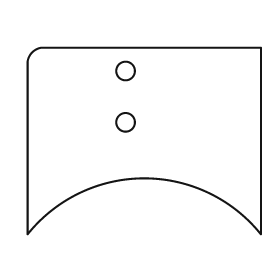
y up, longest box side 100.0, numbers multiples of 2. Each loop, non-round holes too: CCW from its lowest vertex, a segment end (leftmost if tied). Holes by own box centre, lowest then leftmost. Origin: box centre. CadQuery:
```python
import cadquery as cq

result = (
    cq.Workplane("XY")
    .moveTo(-50.0, -40.0)
    .threePointArc((0.0, -16.0), (50.0, -40.0))
    .lineTo(50.0, 40.0)
    .lineTo(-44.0, 40.0)
    .threePointArc((-48.0, 38.0), (-50.0, 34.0))
    .close()
    .moveTo(-8.0, 8.0)
    .circle(4.0)
    .moveTo(-8.0, 30.0)
    .circle(4.0)
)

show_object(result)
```